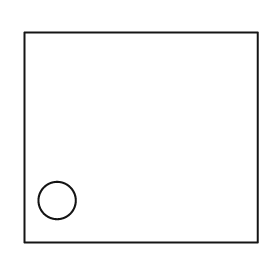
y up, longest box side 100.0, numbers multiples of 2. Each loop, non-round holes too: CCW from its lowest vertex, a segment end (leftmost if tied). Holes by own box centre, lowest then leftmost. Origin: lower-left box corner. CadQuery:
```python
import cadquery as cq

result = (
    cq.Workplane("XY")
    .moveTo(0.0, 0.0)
    .lineTo(100.0, 0.0)
    .lineTo(100.0, 90.0)
    .lineTo(0.0, 90.0)
    .close()
    .moveTo(14.0, 18.0)
    .circle(8.0)
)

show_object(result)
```